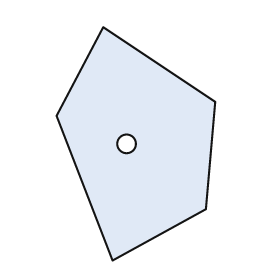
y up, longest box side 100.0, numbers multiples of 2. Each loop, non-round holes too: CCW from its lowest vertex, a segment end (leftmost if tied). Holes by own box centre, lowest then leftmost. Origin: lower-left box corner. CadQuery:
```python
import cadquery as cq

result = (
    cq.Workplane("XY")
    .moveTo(24.0, 0.0)
    .lineTo(64.0, 22.0)
    .lineTo(68.0, 68.0)
    .lineTo(20.0, 100.0)
    .lineTo(0.0, 62.0)
    .close()
    .moveTo(30.0, 50.0)
    .circle(4.0)
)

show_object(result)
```